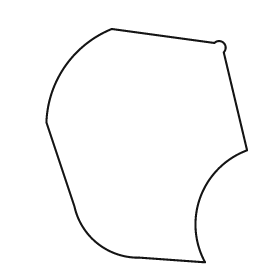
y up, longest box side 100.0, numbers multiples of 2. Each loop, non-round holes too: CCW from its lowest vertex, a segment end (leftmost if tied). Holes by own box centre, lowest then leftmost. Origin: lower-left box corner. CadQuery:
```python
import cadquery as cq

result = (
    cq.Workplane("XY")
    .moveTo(68.0, 0.0)
    .threePointArc((66.0, 28.0), (86.0, 48.0))
    .lineTo(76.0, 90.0)
    .threePointArc((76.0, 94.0), (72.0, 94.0))
    .lineTo(28.0, 100.0)
    .threePointArc((8.0, 84.0), (0.0, 60.0))
    .lineTo(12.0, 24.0)
    .threePointArc((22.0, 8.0), (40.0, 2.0))
    .close()
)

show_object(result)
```